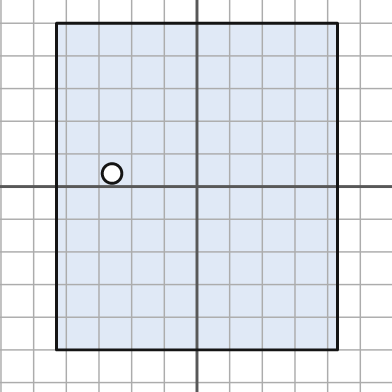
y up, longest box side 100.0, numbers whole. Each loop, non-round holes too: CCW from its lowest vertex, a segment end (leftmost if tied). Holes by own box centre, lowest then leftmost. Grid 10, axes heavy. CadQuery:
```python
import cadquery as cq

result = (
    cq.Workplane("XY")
    .moveTo(-43.0, -50.0)
    .lineTo(43.0, -50.0)
    .lineTo(43.0, 50.0)
    .lineTo(-43.0, 50.0)
    .close()
    .moveTo(-26.0, 4.0)
    .circle(3.0)
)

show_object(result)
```